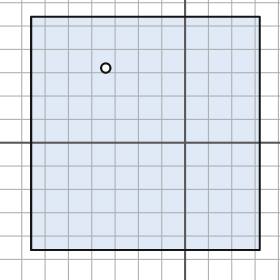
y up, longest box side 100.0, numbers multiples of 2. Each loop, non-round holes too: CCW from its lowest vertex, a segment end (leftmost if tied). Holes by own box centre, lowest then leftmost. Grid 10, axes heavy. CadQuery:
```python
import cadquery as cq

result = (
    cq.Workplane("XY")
    .moveTo(-66.0, -46.0)
    .lineTo(32.0, -46.0)
    .lineTo(32.0, 54.0)
    .lineTo(-66.0, 54.0)
    .close()
    .moveTo(-34.0, 32.0)
    .circle(2.0)
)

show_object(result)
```